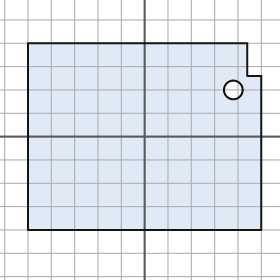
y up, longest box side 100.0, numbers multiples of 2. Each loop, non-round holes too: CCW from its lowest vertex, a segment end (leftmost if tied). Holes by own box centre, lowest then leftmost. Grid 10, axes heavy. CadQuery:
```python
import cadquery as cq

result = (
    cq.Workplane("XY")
    .moveTo(-50.0, -40.0)
    .lineTo(50.0, -40.0)
    .lineTo(50.0, 26.0)
    .lineTo(44.0, 26.0)
    .lineTo(44.0, 40.0)
    .lineTo(-50.0, 40.0)
    .close()
    .moveTo(38.0, 20.0)
    .circle(4.0)
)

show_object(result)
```